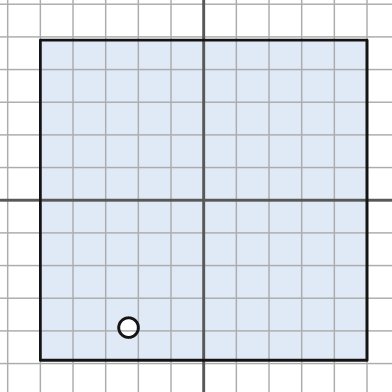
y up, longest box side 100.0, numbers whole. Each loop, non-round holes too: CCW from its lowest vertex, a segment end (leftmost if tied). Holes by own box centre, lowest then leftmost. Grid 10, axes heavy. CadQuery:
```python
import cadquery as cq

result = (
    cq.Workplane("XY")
    .moveTo(-50.0, -49.0)
    .lineTo(50.0, -49.0)
    .lineTo(50.0, 49.0)
    .lineTo(-50.0, 49.0)
    .close()
    .moveTo(-23.0, -39.0)
    .circle(3.0)
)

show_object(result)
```